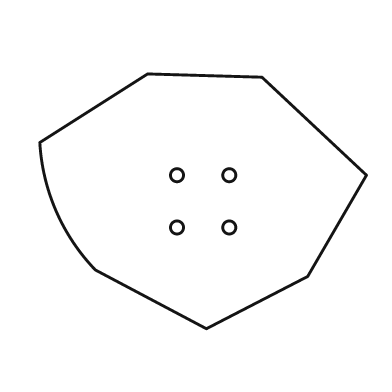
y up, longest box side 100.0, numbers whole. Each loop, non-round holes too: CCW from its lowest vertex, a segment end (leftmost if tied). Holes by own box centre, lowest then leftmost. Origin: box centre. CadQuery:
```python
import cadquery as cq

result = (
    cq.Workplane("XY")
    .moveTo(1.0, -39.0)
    .lineTo(32.0, -23.0)
    .lineTo(50.0, 8.0)
    .lineTo(18.0, 38.0)
    .lineTo(-17.0, 39.0)
    .lineTo(-50.0, 18.0)
    .threePointArc((-45.0, -3.0), (-33.0, -21.0))
    .close()
    .moveTo(-8.0, -8.0)
    .circle(2.0)
    .moveTo(8.0, -8.0)
    .circle(2.0)
    .moveTo(-8.0, 8.0)
    .circle(2.0)
    .moveTo(8.0, 8.0)
    .circle(2.0)
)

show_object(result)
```